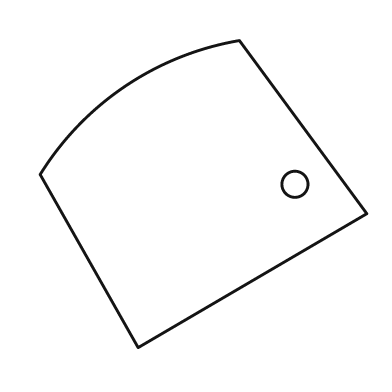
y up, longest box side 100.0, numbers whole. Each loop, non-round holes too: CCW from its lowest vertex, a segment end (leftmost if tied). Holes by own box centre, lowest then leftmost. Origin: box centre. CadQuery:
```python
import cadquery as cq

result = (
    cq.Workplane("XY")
    .moveTo(-20.0, -47.0)
    .lineTo(50.0, -6.0)
    .lineTo(11.0, 47.0)
    .threePointArc((-24.0, 33.0), (-50.0, 6.0))
    .close()
    .moveTo(28.0, 3.0)
    .circle(4.0)
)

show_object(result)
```